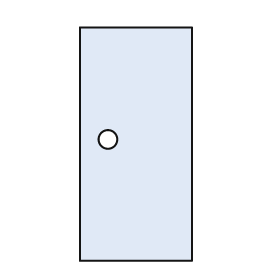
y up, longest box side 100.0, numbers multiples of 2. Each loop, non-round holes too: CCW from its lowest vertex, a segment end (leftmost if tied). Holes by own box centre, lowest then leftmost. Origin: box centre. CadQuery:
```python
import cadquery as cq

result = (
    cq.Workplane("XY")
    .moveTo(-24.0, -50.0)
    .lineTo(24.0, -50.0)
    .lineTo(24.0, 50.0)
    .lineTo(-24.0, 50.0)
    .close()
    .moveTo(-12.0, 2.0)
    .circle(4.0)
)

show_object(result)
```